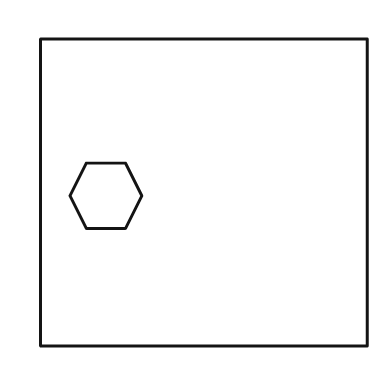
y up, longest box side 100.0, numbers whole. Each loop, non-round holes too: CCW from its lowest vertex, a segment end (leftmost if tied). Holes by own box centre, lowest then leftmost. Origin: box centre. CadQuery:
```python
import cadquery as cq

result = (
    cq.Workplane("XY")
    .moveTo(-50.0, -47.0)
    .lineTo(50.0, -47.0)
    .lineTo(50.0, 47.0)
    .lineTo(-50.0, 47.0)
    .close()
    .moveTo(-36.0, -11.0)
    .lineTo(-24.0, -11.0)
    .lineTo(-19.0, -1.0)
    .lineTo(-24.0, 9.0)
    .lineTo(-36.0, 9.0)
    .lineTo(-41.0, -1.0)
    .close()
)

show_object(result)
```